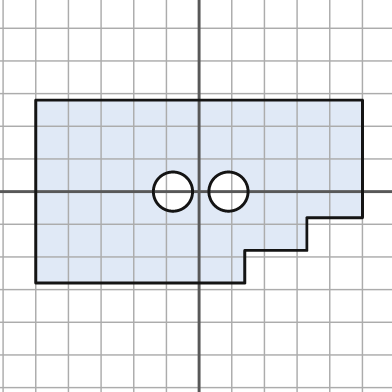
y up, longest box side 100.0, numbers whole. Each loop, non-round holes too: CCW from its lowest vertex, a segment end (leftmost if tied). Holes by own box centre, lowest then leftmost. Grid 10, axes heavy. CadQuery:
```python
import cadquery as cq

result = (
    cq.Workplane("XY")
    .moveTo(-50.0, -28.0)
    .lineTo(14.0, -28.0)
    .lineTo(14.0, -18.0)
    .lineTo(33.0, -18.0)
    .lineTo(33.0, -8.0)
    .lineTo(50.0, -8.0)
    .lineTo(50.0, 28.0)
    .lineTo(-50.0, 28.0)
    .close()
    .moveTo(-8.0, 0.0)
    .circle(6.0)
    .moveTo(9.0, 0.0)
    .circle(6.0)
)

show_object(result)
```